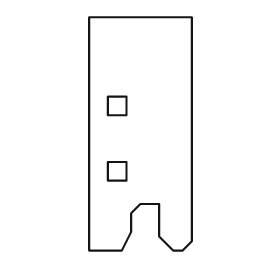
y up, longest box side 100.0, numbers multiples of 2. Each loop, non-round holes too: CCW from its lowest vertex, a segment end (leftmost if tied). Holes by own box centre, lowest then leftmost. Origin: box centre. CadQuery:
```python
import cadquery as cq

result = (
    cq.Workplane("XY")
    .moveTo(-22.0, -50.0)
    .lineTo(-8.0, -50.0)
    .lineTo(-4.0, -42.0)
    .lineTo(-4.0, -34.0)
    .lineTo(0.0, -30.0)
    .lineTo(8.0, -30.0)
    .lineTo(8.0, -44.0)
    .lineTo(14.0, -50.0)
    .lineTo(18.0, -50.0)
    .lineTo(22.0, -46.0)
    .lineTo(22.0, 50.0)
    .lineTo(-22.0, 50.0)
    .close()
    .moveTo(-14.0, -20.0)
    .lineTo(-6.0, -20.0)
    .lineTo(-6.0, -12.0)
    .lineTo(-14.0, -12.0)
    .close()
    .moveTo(-14.0, 8.0)
    .lineTo(-6.0, 8.0)
    .lineTo(-6.0, 16.0)
    .lineTo(-14.0, 16.0)
    .close()
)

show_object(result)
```